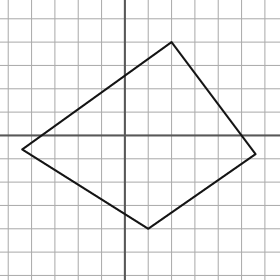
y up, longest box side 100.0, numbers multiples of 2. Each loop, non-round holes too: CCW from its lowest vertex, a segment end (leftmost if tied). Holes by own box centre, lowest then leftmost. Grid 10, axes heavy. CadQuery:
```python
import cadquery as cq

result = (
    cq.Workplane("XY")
    .moveTo(10.0, -40.0)
    .lineTo(56.0, -8.0)
    .lineTo(20.0, 40.0)
    .lineTo(-44.0, -6.0)
    .close()
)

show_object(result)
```